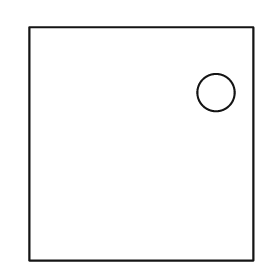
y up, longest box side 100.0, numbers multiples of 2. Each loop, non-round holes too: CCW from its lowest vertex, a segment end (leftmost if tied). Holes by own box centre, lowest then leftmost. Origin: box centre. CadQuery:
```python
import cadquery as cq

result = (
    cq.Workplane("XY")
    .moveTo(-48.0, -50.0)
    .lineTo(48.0, -50.0)
    .lineTo(48.0, 50.0)
    .lineTo(-48.0, 50.0)
    .close()
    .moveTo(32.0, 22.0)
    .circle(8.0)
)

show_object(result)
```